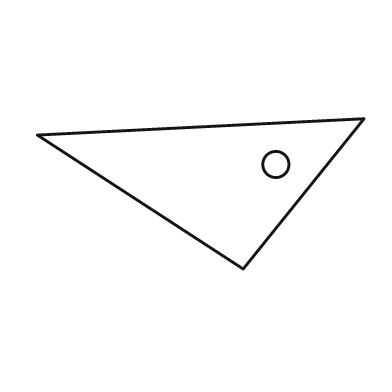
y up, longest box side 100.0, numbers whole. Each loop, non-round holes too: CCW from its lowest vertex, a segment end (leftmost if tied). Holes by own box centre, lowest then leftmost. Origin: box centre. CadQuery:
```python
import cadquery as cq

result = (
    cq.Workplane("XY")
    .moveTo(13.0, -23.0)
    .lineTo(50.0, 23.0)
    .lineTo(-50.0, 18.0)
    .close()
    .moveTo(23.0, 9.0)
    .circle(4.0)
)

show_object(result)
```